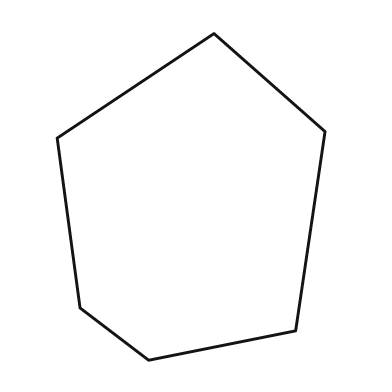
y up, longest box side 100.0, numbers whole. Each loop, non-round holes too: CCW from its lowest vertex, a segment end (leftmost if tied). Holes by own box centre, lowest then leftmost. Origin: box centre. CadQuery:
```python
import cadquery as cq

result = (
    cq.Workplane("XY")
    .moveTo(-13.0, -50.0)
    .lineTo(32.0, -41.0)
    .lineTo(41.0, 20.0)
    .lineTo(7.0, 50.0)
    .lineTo(-41.0, 18.0)
    .lineTo(-34.0, -34.0)
    .close()
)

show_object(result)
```